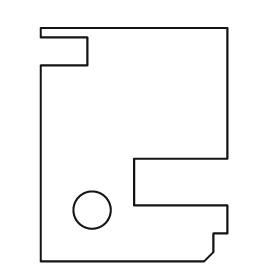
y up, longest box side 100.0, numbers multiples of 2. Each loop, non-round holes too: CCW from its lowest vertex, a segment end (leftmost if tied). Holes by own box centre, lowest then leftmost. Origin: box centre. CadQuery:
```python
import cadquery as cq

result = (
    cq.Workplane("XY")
    .moveTo(-40.0, -50.0)
    .lineTo(30.0, -50.0)
    .lineTo(34.0, -46.0)
    .lineTo(34.0, -38.0)
    .lineTo(40.0, -38.0)
    .lineTo(40.0, -26.0)
    .lineTo(0.0, -26.0)
    .lineTo(0.0, -6.0)
    .lineTo(40.0, -6.0)
    .lineTo(40.0, 50.0)
    .lineTo(-40.0, 50.0)
    .lineTo(-40.0, 46.0)
    .lineTo(-20.0, 46.0)
    .lineTo(-20.0, 34.0)
    .lineTo(-40.0, 34.0)
    .close()
    .moveTo(-18.0, -28.0)
    .circle(8.0)
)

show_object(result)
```